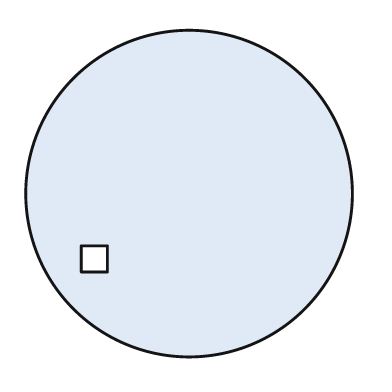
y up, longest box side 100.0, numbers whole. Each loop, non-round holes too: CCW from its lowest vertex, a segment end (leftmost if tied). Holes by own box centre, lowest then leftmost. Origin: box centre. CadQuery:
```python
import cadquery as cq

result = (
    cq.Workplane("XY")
    .moveTo(0.0, 0.0)
    .circle(50.0)
    .moveTo(-33.0, -24.0)
    .lineTo(-25.0, -24.0)
    .lineTo(-25.0, -16.0)
    .lineTo(-33.0, -16.0)
    .close()
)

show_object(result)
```